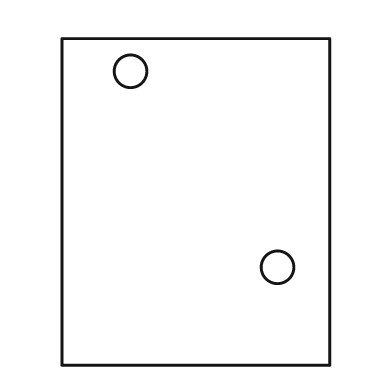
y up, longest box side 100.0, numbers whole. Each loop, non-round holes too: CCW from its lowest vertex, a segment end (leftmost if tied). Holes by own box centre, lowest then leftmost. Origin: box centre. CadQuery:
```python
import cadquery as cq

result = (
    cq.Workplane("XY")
    .moveTo(-41.0, -50.0)
    .lineTo(41.0, -50.0)
    .lineTo(41.0, 50.0)
    .lineTo(-41.0, 50.0)
    .close()
    .moveTo(25.0, -20.0)
    .circle(5.0)
    .moveTo(-20.0, 40.0)
    .circle(5.0)
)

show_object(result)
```